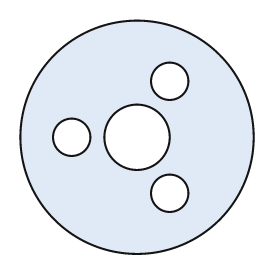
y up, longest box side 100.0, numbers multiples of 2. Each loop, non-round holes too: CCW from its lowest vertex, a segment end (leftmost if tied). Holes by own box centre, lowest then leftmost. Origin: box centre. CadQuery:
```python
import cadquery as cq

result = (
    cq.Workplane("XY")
    .moveTo(0.0, 0.0)
    .circle(50.0)
    .moveTo(14.0, -24.0)
    .circle(8.0)
    .moveTo(-28.0, 0.0)
    .circle(8.0)
    .moveTo(0.0, 0.0)
    .circle(14.0)
    .moveTo(14.0, 24.0)
    .circle(8.0)
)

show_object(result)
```